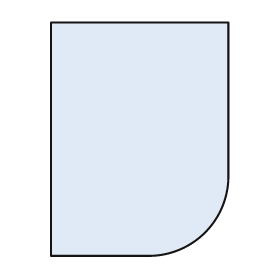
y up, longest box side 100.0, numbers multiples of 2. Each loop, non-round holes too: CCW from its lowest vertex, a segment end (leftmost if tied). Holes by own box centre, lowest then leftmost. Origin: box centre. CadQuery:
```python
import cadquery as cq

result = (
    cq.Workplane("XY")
    .moveTo(-38.0, -50.0)
    .lineTo(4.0, -50.0)
    .threePointArc((28.0, -40.0), (38.0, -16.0))
    .lineTo(38.0, 50.0)
    .lineTo(-38.0, 50.0)
    .close()
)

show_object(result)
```